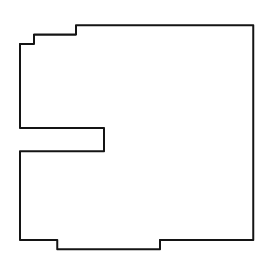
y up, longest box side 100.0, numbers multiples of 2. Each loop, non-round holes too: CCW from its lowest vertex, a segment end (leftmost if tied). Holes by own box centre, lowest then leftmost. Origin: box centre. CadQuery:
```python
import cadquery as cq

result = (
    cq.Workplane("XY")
    .moveTo(-34.0, -48.0)
    .lineTo(10.0, -48.0)
    .lineTo(10.0, -44.0)
    .lineTo(50.0, -44.0)
    .lineTo(50.0, 48.0)
    .lineTo(-26.0, 48.0)
    .lineTo(-26.0, 44.0)
    .lineTo(-44.0, 44.0)
    .lineTo(-44.0, 40.0)
    .lineTo(-50.0, 40.0)
    .lineTo(-50.0, 4.0)
    .lineTo(-14.0, 4.0)
    .lineTo(-14.0, -6.0)
    .lineTo(-50.0, -6.0)
    .lineTo(-50.0, -44.0)
    .lineTo(-34.0, -44.0)
    .close()
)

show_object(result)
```